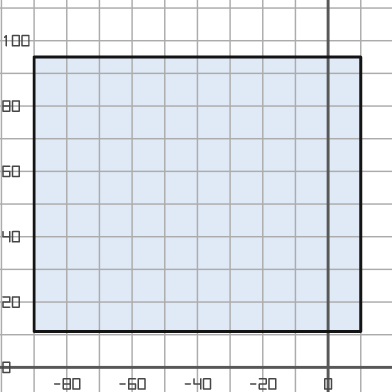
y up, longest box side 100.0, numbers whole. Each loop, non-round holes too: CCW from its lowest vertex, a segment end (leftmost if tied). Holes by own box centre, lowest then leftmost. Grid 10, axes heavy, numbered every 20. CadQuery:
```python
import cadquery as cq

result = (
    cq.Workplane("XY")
    .moveTo(-90.0, 11.0)
    .lineTo(10.0, 11.0)
    .lineTo(10.0, 95.0)
    .lineTo(-90.0, 95.0)
    .close()
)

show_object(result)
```